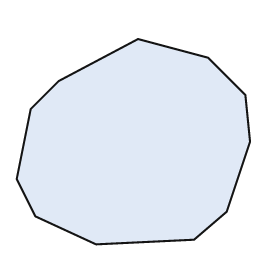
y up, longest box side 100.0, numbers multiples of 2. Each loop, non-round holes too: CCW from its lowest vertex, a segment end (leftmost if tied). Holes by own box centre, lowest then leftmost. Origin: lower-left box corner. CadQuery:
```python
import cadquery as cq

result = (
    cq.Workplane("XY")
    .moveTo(34.0, 0.0)
    .lineTo(76.0, 2.0)
    .lineTo(90.0, 14.0)
    .lineTo(100.0, 44.0)
    .lineTo(98.0, 64.0)
    .lineTo(82.0, 80.0)
    .lineTo(52.0, 88.0)
    .lineTo(18.0, 70.0)
    .lineTo(6.0, 58.0)
    .lineTo(0.0, 28.0)
    .lineTo(8.0, 12.0)
    .close()
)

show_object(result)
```